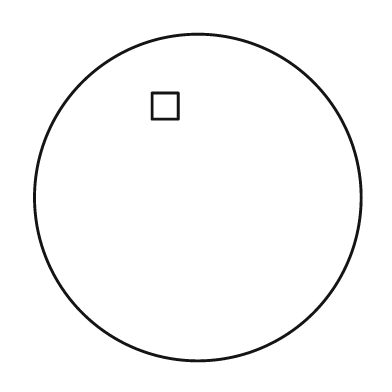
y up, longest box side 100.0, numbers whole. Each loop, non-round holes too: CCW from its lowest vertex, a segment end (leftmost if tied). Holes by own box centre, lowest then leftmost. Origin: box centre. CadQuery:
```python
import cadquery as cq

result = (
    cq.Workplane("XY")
    .moveTo(0.0, 0.0)
    .circle(50.0)
    .moveTo(-14.0, 24.0)
    .lineTo(-6.0, 24.0)
    .lineTo(-6.0, 32.0)
    .lineTo(-14.0, 32.0)
    .close()
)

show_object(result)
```